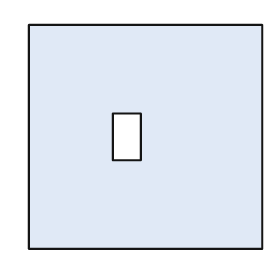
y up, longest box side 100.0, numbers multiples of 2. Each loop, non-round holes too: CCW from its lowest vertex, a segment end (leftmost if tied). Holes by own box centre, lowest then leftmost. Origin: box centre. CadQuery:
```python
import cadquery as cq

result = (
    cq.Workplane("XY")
    .moveTo(-50.0, -48.0)
    .lineTo(50.0, -48.0)
    .lineTo(50.0, 48.0)
    .lineTo(-50.0, 48.0)
    .close()
    .moveTo(-14.0, -10.0)
    .lineTo(-2.0, -10.0)
    .lineTo(-2.0, 10.0)
    .lineTo(-14.0, 10.0)
    .close()
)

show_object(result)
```